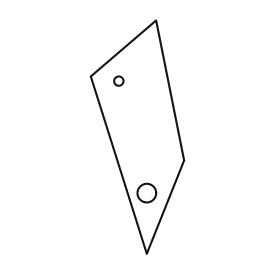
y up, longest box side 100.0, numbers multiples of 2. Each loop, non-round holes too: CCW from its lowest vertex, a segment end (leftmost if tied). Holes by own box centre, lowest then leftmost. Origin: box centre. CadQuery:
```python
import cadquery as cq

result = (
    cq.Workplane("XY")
    .moveTo(4.0, -50.0)
    .lineTo(20.0, -10.0)
    .lineTo(8.0, 50.0)
    .lineTo(-20.0, 26.0)
    .close()
    .moveTo(4.0, -24.0)
    .circle(4.0)
    .moveTo(-8.0, 24.0)
    .circle(2.0)
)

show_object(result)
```